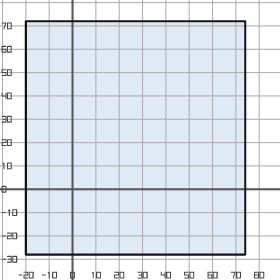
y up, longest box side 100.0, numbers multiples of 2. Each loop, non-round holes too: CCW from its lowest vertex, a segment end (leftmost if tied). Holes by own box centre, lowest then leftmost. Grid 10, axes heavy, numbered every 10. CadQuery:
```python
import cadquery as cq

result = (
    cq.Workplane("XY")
    .moveTo(-20.0, -28.0)
    .lineTo(74.0, -28.0)
    .lineTo(74.0, 72.0)
    .lineTo(-20.0, 72.0)
    .close()
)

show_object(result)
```